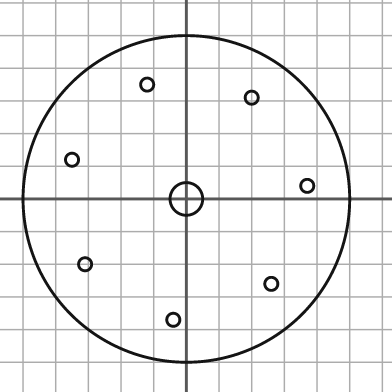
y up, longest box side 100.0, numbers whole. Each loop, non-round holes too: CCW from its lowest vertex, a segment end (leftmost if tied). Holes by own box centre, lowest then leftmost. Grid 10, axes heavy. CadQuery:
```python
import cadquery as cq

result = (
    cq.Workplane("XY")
    .moveTo(0.0, 0.0)
    .circle(50.0)
    .moveTo(-4.0, -37.0)
    .circle(2.0)
    .moveTo(26.0, -26.0)
    .circle(2.0)
    .moveTo(-31.0, -20.0)
    .circle(2.0)
    .moveTo(0.0, 0.0)
    .circle(5.0)
    .moveTo(37.0, 4.0)
    .circle(2.0)
    .moveTo(-35.0, 12.0)
    .circle(2.0)
    .moveTo(20.0, 31.0)
    .circle(2.0)
    .moveTo(-12.0, 35.0)
    .circle(2.0)
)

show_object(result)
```